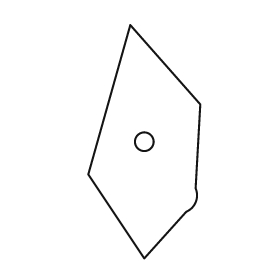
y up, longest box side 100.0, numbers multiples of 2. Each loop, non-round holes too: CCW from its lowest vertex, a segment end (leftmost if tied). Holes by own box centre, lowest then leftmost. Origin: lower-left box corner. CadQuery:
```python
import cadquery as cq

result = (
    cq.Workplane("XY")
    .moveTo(24.0, 0.0)
    .lineTo(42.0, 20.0)
    .threePointArc((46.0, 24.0), (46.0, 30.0))
    .lineTo(48.0, 66.0)
    .lineTo(18.0, 100.0)
    .lineTo(0.0, 36.0)
    .close()
    .moveTo(24.0, 50.0)
    .circle(4.0)
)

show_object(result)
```